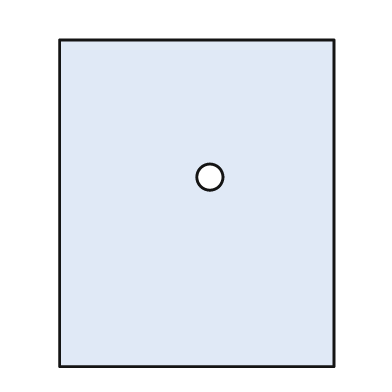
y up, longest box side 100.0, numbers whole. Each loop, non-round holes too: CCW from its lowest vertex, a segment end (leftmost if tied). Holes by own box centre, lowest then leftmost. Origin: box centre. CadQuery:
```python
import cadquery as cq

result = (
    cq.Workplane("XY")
    .moveTo(-42.0, -50.0)
    .lineTo(42.0, -50.0)
    .lineTo(42.0, 50.0)
    .lineTo(-42.0, 50.0)
    .close()
    .moveTo(4.0, 8.0)
    .circle(4.0)
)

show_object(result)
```